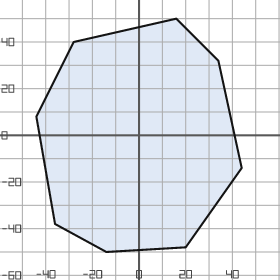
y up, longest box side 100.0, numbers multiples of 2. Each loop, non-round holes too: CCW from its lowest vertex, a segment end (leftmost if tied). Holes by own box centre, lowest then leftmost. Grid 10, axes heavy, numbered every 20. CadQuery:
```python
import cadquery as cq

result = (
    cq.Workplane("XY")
    .moveTo(-14.0, -50.0)
    .lineTo(20.0, -48.0)
    .lineTo(44.0, -14.0)
    .lineTo(34.0, 32.0)
    .lineTo(16.0, 50.0)
    .lineTo(-28.0, 40.0)
    .lineTo(-44.0, 8.0)
    .lineTo(-36.0, -38.0)
    .close()
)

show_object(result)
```